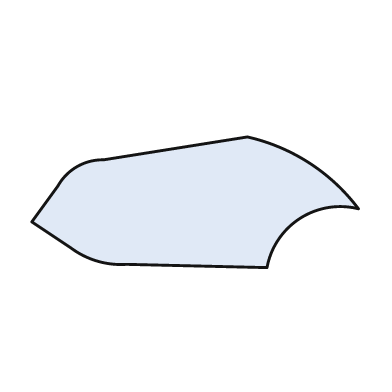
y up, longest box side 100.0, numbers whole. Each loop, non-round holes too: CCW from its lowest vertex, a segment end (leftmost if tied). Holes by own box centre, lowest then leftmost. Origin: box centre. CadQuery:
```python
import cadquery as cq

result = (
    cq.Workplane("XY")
    .moveTo(22.0, -20.0)
    .threePointArc((32.0, -5.0), (50.0, -2.0))
    .threePointArc((35.0, 12.0), (16.0, 20.0))
    .lineTo(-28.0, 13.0)
    .threePointArc((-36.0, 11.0), (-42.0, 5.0))
    .lineTo(-50.0, -6.0)
    .lineTo(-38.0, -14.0)
    .threePointArc((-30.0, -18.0), (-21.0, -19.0))
    .close()
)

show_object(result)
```